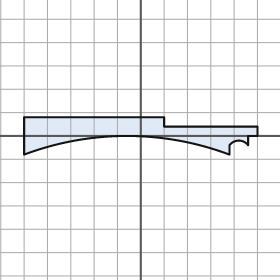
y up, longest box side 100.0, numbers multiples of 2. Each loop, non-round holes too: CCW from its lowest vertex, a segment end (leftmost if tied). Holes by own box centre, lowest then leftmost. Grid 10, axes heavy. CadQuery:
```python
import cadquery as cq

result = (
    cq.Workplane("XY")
    .moveTo(-50.0, -8.0)
    .threePointArc((-6.0, 0.0), (38.0, -8.0))
    .lineTo(38.0, -4.0)
    .threePointArc((42.0, -2.0), (46.0, -4.0))
    .lineTo(46.0, 0.0)
    .lineTo(50.0, 0.0)
    .lineTo(50.0, 4.0)
    .lineTo(10.0, 4.0)
    .lineTo(10.0, 8.0)
    .lineTo(-50.0, 8.0)
    .close()
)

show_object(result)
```